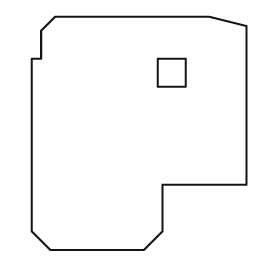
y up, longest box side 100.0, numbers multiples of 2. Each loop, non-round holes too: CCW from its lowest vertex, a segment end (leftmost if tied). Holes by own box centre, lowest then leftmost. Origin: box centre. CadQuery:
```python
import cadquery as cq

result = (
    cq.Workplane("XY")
    .moveTo(-38.0, -50.0)
    .lineTo(2.0, -50.0)
    .lineTo(10.0, -42.0)
    .lineTo(10.0, -22.0)
    .lineTo(46.0, -22.0)
    .lineTo(46.0, 46.0)
    .lineTo(30.0, 50.0)
    .lineTo(-36.0, 50.0)
    .lineTo(-42.0, 44.0)
    .lineTo(-42.0, 32.0)
    .lineTo(-46.0, 32.0)
    .lineTo(-46.0, -42.0)
    .close()
    .moveTo(8.0, 20.0)
    .lineTo(20.0, 20.0)
    .lineTo(20.0, 32.0)
    .lineTo(8.0, 32.0)
    .close()
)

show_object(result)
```